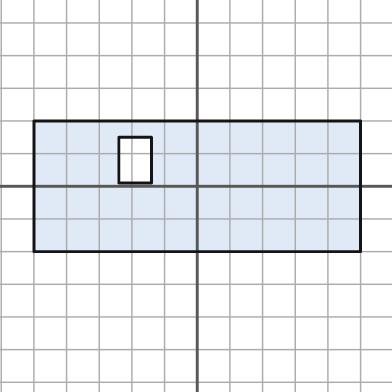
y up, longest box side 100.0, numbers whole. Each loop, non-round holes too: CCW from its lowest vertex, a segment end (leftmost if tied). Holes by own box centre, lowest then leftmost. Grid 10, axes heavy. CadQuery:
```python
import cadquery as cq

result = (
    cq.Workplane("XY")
    .moveTo(-50.0, -20.0)
    .lineTo(50.0, -20.0)
    .lineTo(50.0, 20.0)
    .lineTo(-50.0, 20.0)
    .close()
    .moveTo(-24.0, 1.0)
    .lineTo(-14.0, 1.0)
    .lineTo(-14.0, 15.0)
    .lineTo(-24.0, 15.0)
    .close()
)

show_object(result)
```